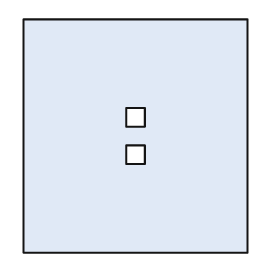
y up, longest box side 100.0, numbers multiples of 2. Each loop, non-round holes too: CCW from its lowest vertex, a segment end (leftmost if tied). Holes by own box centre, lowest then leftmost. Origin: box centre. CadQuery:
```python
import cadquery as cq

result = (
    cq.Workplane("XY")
    .moveTo(-48.0, -50.0)
    .lineTo(48.0, -50.0)
    .lineTo(48.0, 50.0)
    .lineTo(-48.0, 50.0)
    .close()
    .moveTo(-4.0, -12.0)
    .lineTo(4.0, -12.0)
    .lineTo(4.0, -4.0)
    .lineTo(-4.0, -4.0)
    .close()
    .moveTo(-4.0, 4.0)
    .lineTo(4.0, 4.0)
    .lineTo(4.0, 12.0)
    .lineTo(-4.0, 12.0)
    .close()
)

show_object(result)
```